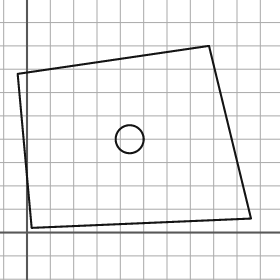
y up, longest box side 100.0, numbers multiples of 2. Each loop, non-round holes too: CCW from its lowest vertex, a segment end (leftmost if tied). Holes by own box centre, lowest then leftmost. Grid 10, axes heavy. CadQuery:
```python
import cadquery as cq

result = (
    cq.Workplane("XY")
    .moveTo(2.0, 2.0)
    .lineTo(96.0, 6.0)
    .lineTo(78.0, 80.0)
    .lineTo(-4.0, 68.0)
    .close()
    .moveTo(44.0, 40.0)
    .circle(6.0)
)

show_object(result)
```